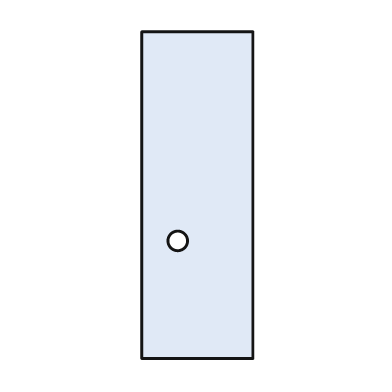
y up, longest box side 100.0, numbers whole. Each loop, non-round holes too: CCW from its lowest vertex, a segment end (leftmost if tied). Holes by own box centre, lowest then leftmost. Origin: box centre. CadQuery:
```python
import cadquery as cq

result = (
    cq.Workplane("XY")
    .moveTo(-17.0, -50.0)
    .lineTo(17.0, -50.0)
    .lineTo(17.0, 50.0)
    .lineTo(-17.0, 50.0)
    .close()
    .moveTo(-6.0, -14.0)
    .circle(3.0)
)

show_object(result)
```